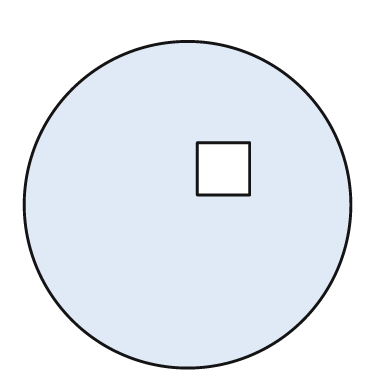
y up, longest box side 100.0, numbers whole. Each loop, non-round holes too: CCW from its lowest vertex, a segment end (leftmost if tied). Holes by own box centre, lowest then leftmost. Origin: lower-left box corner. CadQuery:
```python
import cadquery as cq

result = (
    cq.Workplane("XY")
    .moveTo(50.0, 50.0)
    .circle(50.0)
    .moveTo(53.0, 53.0)
    .lineTo(69.0, 53.0)
    .lineTo(69.0, 69.0)
    .lineTo(53.0, 69.0)
    .close()
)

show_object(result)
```